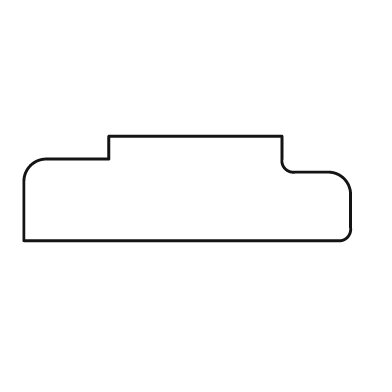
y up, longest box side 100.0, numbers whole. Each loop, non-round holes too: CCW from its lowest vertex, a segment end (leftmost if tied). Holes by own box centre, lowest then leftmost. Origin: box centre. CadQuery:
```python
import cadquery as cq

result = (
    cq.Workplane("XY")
    .moveTo(-50.0, -16.0)
    .lineTo(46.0, -16.0)
    .threePointArc((49.0, -15.0), (50.0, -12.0))
    .lineTo(50.0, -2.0)
    .threePointArc((48.0, 3.0), (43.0, 5.0))
    .lineTo(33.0, 5.0)
    .threePointArc((30.0, 6.0), (29.0, 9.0))
    .lineTo(29.0, 16.0)
    .lineTo(-24.0, 16.0)
    .lineTo(-24.0, 9.0)
    .lineTo(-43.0, 9.0)
    .threePointArc((-48.0, 7.0), (-50.0, 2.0))
    .close()
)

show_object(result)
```